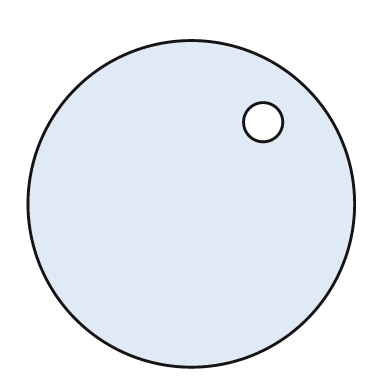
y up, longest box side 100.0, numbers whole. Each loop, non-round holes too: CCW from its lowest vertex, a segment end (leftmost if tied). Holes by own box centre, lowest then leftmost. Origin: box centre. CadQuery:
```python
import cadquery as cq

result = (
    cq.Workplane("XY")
    .moveTo(0.0, 0.0)
    .circle(50.0)
    .moveTo(22.0, 25.0)
    .circle(6.0)
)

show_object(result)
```